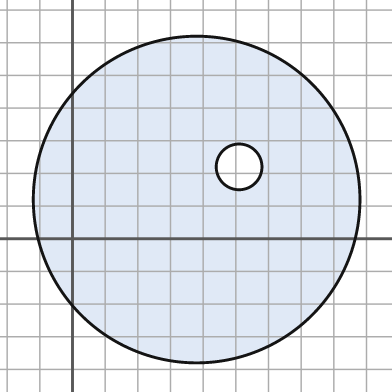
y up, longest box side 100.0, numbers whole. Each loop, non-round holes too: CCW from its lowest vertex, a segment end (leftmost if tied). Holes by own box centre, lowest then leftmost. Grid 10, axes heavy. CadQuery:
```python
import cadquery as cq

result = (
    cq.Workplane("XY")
    .moveTo(38.0, 12.0)
    .circle(50.0)
    .moveTo(51.0, 22.0)
    .circle(7.0)
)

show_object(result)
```